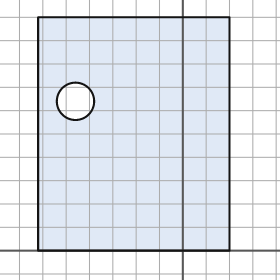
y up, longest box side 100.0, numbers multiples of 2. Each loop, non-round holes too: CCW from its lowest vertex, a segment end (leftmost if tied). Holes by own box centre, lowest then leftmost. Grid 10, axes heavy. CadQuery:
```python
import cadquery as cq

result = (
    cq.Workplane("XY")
    .moveTo(-62.0, 0.0)
    .lineTo(20.0, 0.0)
    .lineTo(20.0, 100.0)
    .lineTo(-62.0, 100.0)
    .close()
    .moveTo(-46.0, 64.0)
    .circle(8.0)
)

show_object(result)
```